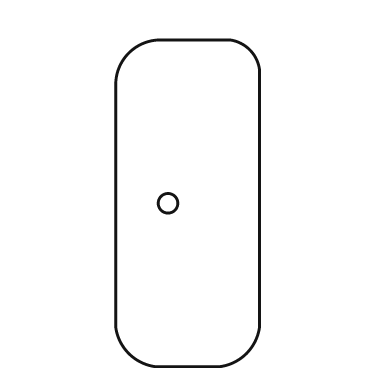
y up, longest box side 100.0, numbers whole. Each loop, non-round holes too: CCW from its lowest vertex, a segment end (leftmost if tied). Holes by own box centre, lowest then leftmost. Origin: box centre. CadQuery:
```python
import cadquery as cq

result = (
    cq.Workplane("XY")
    .moveTo(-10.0, -50.0)
    .lineTo(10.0, -50.0)
    .threePointArc((18.0, -46.0), (22.0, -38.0))
    .lineTo(22.0, 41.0)
    .threePointArc((19.0, 47.0), (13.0, 50.0))
    .lineTo(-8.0, 50.0)
    .threePointArc((-18.0, 46.0), (-22.0, 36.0))
    .lineTo(-22.0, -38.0)
    .threePointArc((-18.0, -46.0), (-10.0, -50.0))
    .close()
    .moveTo(-6.0, 0.0)
    .circle(3.0)
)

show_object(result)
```